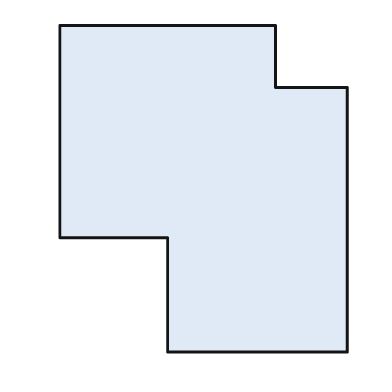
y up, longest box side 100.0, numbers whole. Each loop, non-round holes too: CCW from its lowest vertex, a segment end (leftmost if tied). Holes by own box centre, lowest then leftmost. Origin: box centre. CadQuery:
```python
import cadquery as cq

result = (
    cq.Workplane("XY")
    .moveTo(-11.0, -50.0)
    .lineTo(44.0, -50.0)
    .lineTo(44.0, 31.0)
    .lineTo(22.0, 31.0)
    .lineTo(22.0, 50.0)
    .lineTo(-44.0, 50.0)
    .lineTo(-44.0, -15.0)
    .lineTo(-11.0, -15.0)
    .close()
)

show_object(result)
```